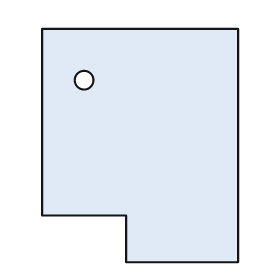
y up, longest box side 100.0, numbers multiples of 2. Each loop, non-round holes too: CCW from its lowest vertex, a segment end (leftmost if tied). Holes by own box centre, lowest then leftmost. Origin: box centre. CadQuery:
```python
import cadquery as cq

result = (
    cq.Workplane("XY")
    .moveTo(-6.0, -50.0)
    .lineTo(42.0, -50.0)
    .lineTo(42.0, 50.0)
    .lineTo(-42.0, 50.0)
    .lineTo(-42.0, -30.0)
    .lineTo(-6.0, -30.0)
    .close()
    .moveTo(-24.0, 28.0)
    .circle(4.0)
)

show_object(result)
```